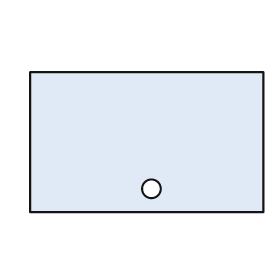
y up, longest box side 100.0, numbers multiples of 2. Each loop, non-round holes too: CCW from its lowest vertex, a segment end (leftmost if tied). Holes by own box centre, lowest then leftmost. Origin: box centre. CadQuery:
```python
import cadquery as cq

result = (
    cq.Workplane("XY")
    .moveTo(-50.0, -30.0)
    .lineTo(50.0, -30.0)
    .lineTo(50.0, 30.0)
    .lineTo(-50.0, 30.0)
    .close()
    .moveTo(2.0, -20.0)
    .circle(4.0)
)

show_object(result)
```